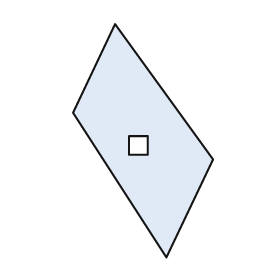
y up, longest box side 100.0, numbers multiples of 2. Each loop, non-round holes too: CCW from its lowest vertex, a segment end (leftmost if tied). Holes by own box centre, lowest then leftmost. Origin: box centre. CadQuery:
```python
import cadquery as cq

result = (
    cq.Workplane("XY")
    .moveTo(10.0, -50.0)
    .lineTo(30.0, -8.0)
    .lineTo(-12.0, 50.0)
    .lineTo(-30.0, 12.0)
    .close()
    .moveTo(-6.0, -6.0)
    .lineTo(2.0, -6.0)
    .lineTo(2.0, 2.0)
    .lineTo(-6.0, 2.0)
    .close()
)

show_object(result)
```